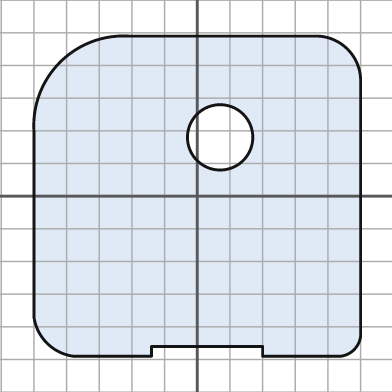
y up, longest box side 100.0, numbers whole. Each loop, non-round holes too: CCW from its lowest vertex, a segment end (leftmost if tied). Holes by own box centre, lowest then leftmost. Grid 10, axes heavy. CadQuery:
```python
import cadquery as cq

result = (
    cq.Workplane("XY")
    .moveTo(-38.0, -49.0)
    .lineTo(-14.0, -49.0)
    .lineTo(-14.0, -46.0)
    .lineTo(20.0, -46.0)
    .lineTo(20.0, -49.0)
    .lineTo(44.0, -49.0)
    .threePointArc((48.0, -47.0), (50.0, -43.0))
    .lineTo(50.0, 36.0)
    .threePointArc((46.0, 45.0), (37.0, 49.0))
    .lineTo(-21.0, 49.0)
    .threePointArc((-42.0, 41.0), (-50.0, 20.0))
    .lineTo(-50.0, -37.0)
    .threePointArc((-46.0, -45.0), (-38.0, -49.0))
    .close()
    .moveTo(7.0, 18.0)
    .circle(10.0)
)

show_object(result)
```